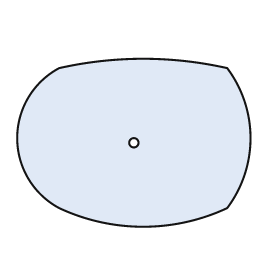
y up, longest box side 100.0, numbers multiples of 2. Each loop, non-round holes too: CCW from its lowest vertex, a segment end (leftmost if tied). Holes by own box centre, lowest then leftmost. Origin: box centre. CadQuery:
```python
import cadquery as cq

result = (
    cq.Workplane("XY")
    .moveTo(-32.0, -28.0)
    .threePointArc((4.0, -36.0), (40.0, -28.0))
    .threePointArc((50.0, 2.0), (40.0, 32.0))
    .threePointArc((4.0, 36.0), (-32.0, 32.0))
    .threePointArc((-50.0, 2.0), (-32.0, -28.0))
    .close()
    .moveTo(0.0, 0.0)
    .circle(2.0)
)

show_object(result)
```